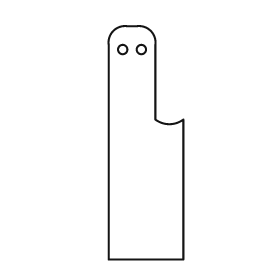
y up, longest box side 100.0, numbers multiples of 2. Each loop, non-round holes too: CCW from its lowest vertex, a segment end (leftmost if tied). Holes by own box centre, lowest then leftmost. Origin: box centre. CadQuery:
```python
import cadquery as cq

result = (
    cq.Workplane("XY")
    .moveTo(-16.0, -50.0)
    .lineTo(16.0, -50.0)
    .lineTo(16.0, 10.0)
    .threePointArc((10.0, 8.0), (4.0, 10.0))
    .lineTo(4.0, 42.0)
    .threePointArc((2.0, 48.0), (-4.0, 50.0))
    .lineTo(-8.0, 50.0)
    .threePointArc((-14.0, 48.0), (-16.0, 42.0))
    .close()
    .moveTo(-10.0, 40.0)
    .circle(2.0)
    .moveTo(-2.0, 40.0)
    .circle(2.0)
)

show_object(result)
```